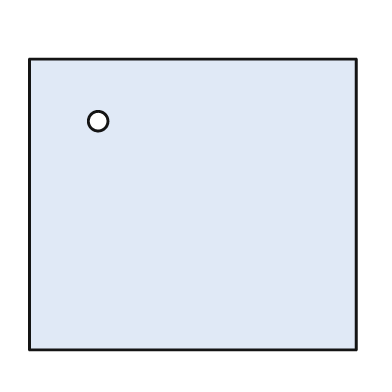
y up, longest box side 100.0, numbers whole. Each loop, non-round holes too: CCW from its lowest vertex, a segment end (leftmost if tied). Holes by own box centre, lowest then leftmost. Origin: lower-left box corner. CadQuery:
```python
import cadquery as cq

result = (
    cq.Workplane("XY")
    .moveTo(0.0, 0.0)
    .lineTo(100.0, 0.0)
    .lineTo(100.0, 89.0)
    .lineTo(0.0, 89.0)
    .close()
    .moveTo(21.0, 70.0)
    .circle(3.0)
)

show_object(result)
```